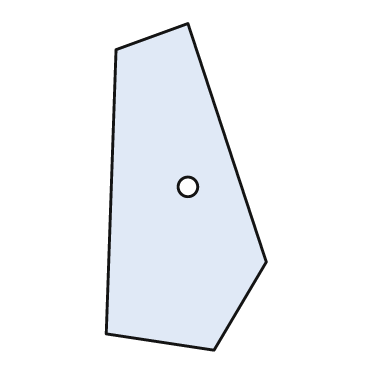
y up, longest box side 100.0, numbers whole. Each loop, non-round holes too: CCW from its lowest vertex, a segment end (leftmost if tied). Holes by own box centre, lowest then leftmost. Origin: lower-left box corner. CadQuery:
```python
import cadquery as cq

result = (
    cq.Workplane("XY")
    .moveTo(33.0, 0.0)
    .lineTo(49.0, 27.0)
    .lineTo(25.0, 100.0)
    .lineTo(3.0, 92.0)
    .lineTo(0.0, 5.0)
    .close()
    .moveTo(25.0, 50.0)
    .circle(3.0)
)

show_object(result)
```